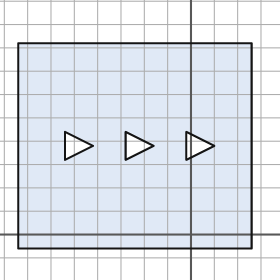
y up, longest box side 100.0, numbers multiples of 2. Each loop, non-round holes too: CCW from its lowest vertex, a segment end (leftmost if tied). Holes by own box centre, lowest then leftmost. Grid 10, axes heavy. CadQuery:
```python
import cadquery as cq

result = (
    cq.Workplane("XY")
    .moveTo(-74.0, -6.0)
    .lineTo(26.0, -6.0)
    .lineTo(26.0, 82.0)
    .lineTo(-74.0, 82.0)
    .close()
    .moveTo(-54.0, 32.0)
    .lineTo(-42.0, 38.0)
    .lineTo(-54.0, 44.0)
    .close()
    .moveTo(-28.0, 32.0)
    .lineTo(-16.0, 38.0)
    .lineTo(-28.0, 44.0)
    .close()
    .moveTo(-2.0, 32.0)
    .lineTo(10.0, 38.0)
    .lineTo(-2.0, 44.0)
    .close()
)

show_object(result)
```